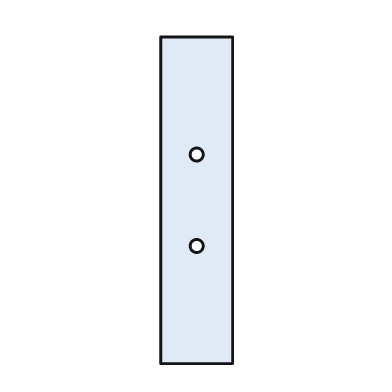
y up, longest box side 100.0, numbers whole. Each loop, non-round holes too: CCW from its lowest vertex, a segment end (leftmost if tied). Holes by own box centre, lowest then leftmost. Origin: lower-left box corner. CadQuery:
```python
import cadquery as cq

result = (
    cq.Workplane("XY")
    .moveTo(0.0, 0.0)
    .lineTo(22.0, 0.0)
    .lineTo(22.0, 100.0)
    .lineTo(0.0, 100.0)
    .close()
    .moveTo(11.0, 36.0)
    .circle(2.0)
    .moveTo(11.0, 64.0)
    .circle(2.0)
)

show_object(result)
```